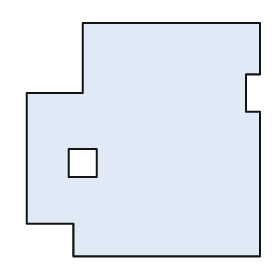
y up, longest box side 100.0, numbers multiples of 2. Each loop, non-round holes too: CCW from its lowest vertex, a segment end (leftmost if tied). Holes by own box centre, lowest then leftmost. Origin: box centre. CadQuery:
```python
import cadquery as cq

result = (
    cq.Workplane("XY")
    .moveTo(-30.0, -50.0)
    .lineTo(50.0, -50.0)
    .lineTo(50.0, 12.0)
    .lineTo(44.0, 12.0)
    .lineTo(44.0, 28.0)
    .lineTo(50.0, 28.0)
    .lineTo(50.0, 50.0)
    .lineTo(-26.0, 50.0)
    .lineTo(-26.0, 20.0)
    .lineTo(-50.0, 20.0)
    .lineTo(-50.0, -36.0)
    .lineTo(-30.0, -36.0)
    .close()
    .moveTo(-32.0, -16.0)
    .lineTo(-20.0, -16.0)
    .lineTo(-20.0, -4.0)
    .lineTo(-32.0, -4.0)
    .close()
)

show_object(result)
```